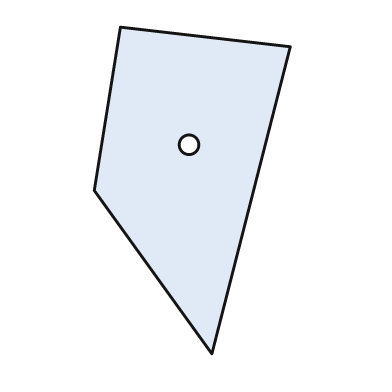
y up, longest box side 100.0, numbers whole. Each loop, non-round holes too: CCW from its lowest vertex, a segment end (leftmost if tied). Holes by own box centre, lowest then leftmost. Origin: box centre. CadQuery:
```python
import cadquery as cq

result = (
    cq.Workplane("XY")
    .moveTo(6.0, -50.0)
    .lineTo(30.0, 44.0)
    .lineTo(-22.0, 50.0)
    .lineTo(-30.0, 0.0)
    .close()
    .moveTo(-1.0, 14.0)
    .circle(3.0)
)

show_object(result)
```